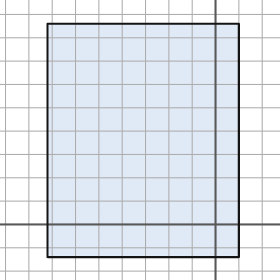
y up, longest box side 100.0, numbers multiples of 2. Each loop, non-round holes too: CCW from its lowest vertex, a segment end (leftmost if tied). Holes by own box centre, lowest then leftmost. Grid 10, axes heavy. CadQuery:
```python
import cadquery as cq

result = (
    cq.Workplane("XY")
    .moveTo(-72.0, -14.0)
    .lineTo(10.0, -14.0)
    .lineTo(10.0, 86.0)
    .lineTo(-72.0, 86.0)
    .close()
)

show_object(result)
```